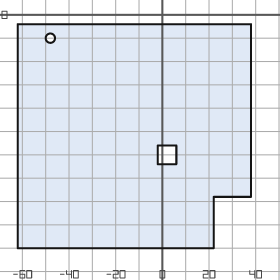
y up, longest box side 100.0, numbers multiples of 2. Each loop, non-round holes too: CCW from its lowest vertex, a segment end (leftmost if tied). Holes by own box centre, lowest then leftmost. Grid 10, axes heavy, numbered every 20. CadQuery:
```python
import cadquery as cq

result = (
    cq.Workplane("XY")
    .moveTo(-62.0, -100.0)
    .lineTo(22.0, -100.0)
    .lineTo(22.0, -78.0)
    .lineTo(38.0, -78.0)
    .lineTo(38.0, -4.0)
    .lineTo(-62.0, -4.0)
    .close()
    .moveTo(-2.0, -64.0)
    .lineTo(6.0, -64.0)
    .lineTo(6.0, -56.0)
    .lineTo(-2.0, -56.0)
    .close()
    .moveTo(-48.0, -10.0)
    .circle(2.0)
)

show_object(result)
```